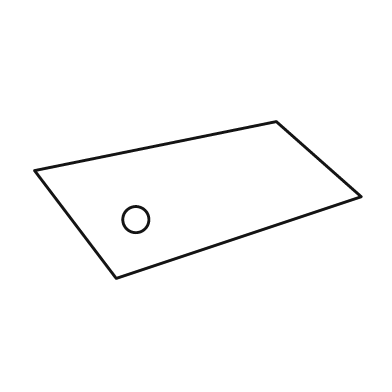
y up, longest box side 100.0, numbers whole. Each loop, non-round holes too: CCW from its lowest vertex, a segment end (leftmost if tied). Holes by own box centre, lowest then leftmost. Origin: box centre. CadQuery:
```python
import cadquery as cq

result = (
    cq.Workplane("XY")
    .moveTo(-25.0, -24.0)
    .lineTo(50.0, 1.0)
    .lineTo(24.0, 24.0)
    .lineTo(-50.0, 9.0)
    .close()
    .moveTo(-19.0, -6.0)
    .circle(4.0)
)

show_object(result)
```